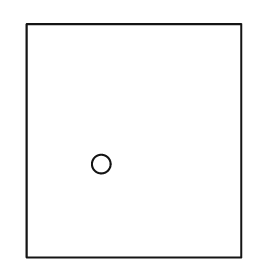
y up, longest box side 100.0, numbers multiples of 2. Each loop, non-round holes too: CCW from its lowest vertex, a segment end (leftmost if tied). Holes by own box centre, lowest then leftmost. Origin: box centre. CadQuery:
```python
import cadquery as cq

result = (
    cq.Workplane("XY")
    .moveTo(-46.0, -50.0)
    .lineTo(46.0, -50.0)
    .lineTo(46.0, 50.0)
    .lineTo(-46.0, 50.0)
    .close()
    .moveTo(-14.0, -10.0)
    .circle(4.0)
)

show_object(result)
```